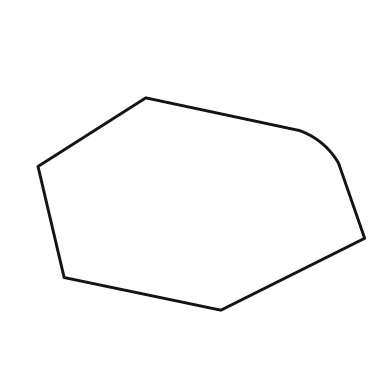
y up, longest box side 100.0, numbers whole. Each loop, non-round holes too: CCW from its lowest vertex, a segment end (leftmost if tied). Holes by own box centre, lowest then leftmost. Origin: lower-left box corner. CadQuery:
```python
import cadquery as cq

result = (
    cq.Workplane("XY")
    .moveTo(56.0, 0.0)
    .lineTo(100.0, 22.0)
    .lineTo(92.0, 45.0)
    .threePointArc((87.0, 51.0), (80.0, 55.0))
    .lineTo(33.0, 65.0)
    .lineTo(0.0, 44.0)
    .lineTo(8.0, 10.0)
    .close()
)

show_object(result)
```